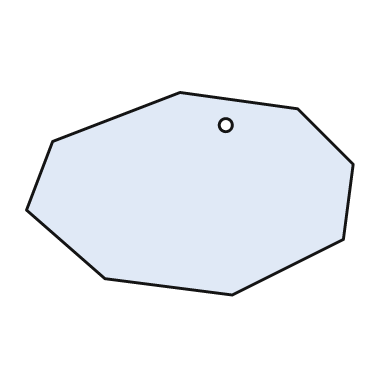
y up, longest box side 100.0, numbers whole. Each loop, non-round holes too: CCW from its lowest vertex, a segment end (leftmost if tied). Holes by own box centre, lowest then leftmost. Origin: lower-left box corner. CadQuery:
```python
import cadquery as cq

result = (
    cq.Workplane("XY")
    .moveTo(63.0, 0.0)
    .lineTo(97.0, 17.0)
    .lineTo(100.0, 40.0)
    .lineTo(83.0, 57.0)
    .lineTo(47.0, 62.0)
    .lineTo(8.0, 47.0)
    .lineTo(0.0, 26.0)
    .lineTo(24.0, 5.0)
    .close()
    .moveTo(61.0, 52.0)
    .circle(2.0)
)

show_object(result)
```